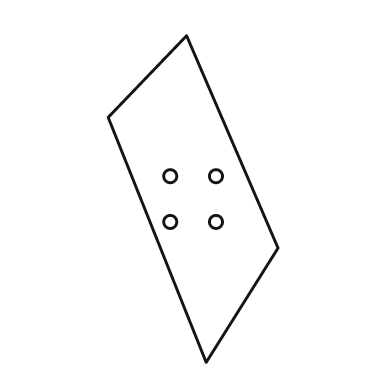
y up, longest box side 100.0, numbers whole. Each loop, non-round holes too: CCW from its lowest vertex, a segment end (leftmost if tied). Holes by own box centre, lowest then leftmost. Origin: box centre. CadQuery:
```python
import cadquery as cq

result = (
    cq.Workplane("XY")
    .moveTo(4.0, -50.0)
    .lineTo(26.0, -15.0)
    .lineTo(-2.0, 50.0)
    .lineTo(-26.0, 25.0)
    .close()
    .moveTo(-7.0, -7.0)
    .circle(2.0)
    .moveTo(7.0, -7.0)
    .circle(2.0)
    .moveTo(-7.0, 7.0)
    .circle(2.0)
    .moveTo(7.0, 7.0)
    .circle(2.0)
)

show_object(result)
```